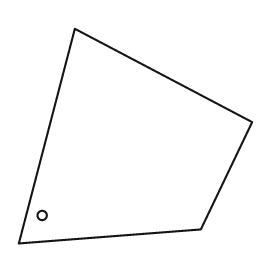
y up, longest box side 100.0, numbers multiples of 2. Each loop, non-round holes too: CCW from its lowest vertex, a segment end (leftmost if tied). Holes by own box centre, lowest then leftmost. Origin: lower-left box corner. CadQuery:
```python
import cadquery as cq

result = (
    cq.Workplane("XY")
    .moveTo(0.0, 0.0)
    .lineTo(78.0, 6.0)
    .lineTo(100.0, 52.0)
    .lineTo(24.0, 92.0)
    .close()
    .moveTo(10.0, 12.0)
    .circle(2.0)
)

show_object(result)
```